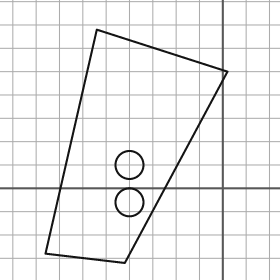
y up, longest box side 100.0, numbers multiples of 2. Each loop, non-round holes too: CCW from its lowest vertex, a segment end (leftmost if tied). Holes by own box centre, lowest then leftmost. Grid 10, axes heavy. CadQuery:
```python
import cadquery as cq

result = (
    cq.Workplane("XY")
    .moveTo(-42.0, -32.0)
    .lineTo(2.0, 50.0)
    .lineTo(-54.0, 68.0)
    .lineTo(-76.0, -28.0)
    .close()
    .moveTo(-40.0, -6.0)
    .circle(6.0)
    .moveTo(-40.0, 10.0)
    .circle(6.0)
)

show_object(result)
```